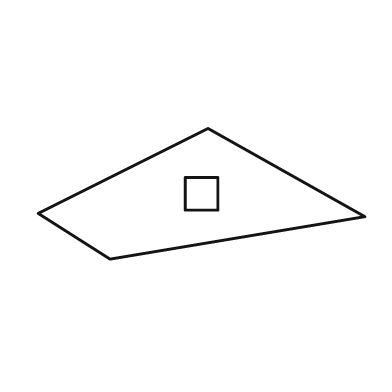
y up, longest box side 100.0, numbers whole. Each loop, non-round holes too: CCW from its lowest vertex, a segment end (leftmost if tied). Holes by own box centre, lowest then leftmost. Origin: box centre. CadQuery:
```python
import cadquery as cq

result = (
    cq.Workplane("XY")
    .moveTo(-28.0, -20.0)
    .lineTo(50.0, -7.0)
    .lineTo(2.0, 20.0)
    .lineTo(-50.0, -6.0)
    .close()
    .moveTo(-5.0, -5.0)
    .lineTo(5.0, -5.0)
    .lineTo(5.0, 5.0)
    .lineTo(-5.0, 5.0)
    .close()
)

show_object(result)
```